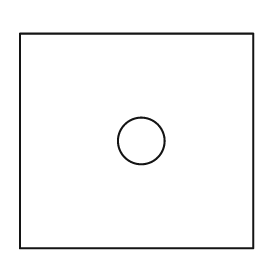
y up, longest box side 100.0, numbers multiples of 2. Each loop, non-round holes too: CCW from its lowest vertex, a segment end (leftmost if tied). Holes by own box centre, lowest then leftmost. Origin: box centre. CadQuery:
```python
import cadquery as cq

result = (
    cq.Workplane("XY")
    .moveTo(-50.0, -46.0)
    .lineTo(50.0, -46.0)
    .lineTo(50.0, 46.0)
    .lineTo(-50.0, 46.0)
    .close()
    .moveTo(2.0, 0.0)
    .circle(10.0)
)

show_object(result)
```